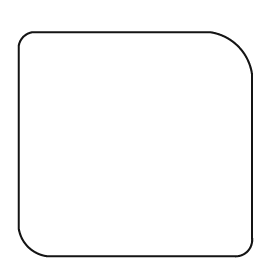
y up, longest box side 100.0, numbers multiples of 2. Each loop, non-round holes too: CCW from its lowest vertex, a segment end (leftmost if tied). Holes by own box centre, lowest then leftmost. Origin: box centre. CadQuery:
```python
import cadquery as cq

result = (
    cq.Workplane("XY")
    .moveTo(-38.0, -48.0)
    .lineTo(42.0, -48.0)
    .threePointArc((48.0, -46.0), (50.0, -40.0))
    .lineTo(50.0, 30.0)
    .threePointArc((44.0, 42.0), (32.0, 48.0))
    .lineTo(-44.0, 48.0)
    .threePointArc((-48.0, 46.0), (-50.0, 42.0))
    .lineTo(-50.0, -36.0)
    .threePointArc((-46.0, -44.0), (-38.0, -48.0))
    .close()
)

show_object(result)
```